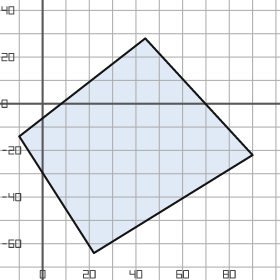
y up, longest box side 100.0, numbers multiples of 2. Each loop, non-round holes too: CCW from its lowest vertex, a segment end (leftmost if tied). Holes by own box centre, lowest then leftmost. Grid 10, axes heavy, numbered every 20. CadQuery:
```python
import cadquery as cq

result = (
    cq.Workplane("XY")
    .moveTo(22.0, -64.0)
    .lineTo(90.0, -22.0)
    .lineTo(44.0, 28.0)
    .lineTo(-10.0, -14.0)
    .close()
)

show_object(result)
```